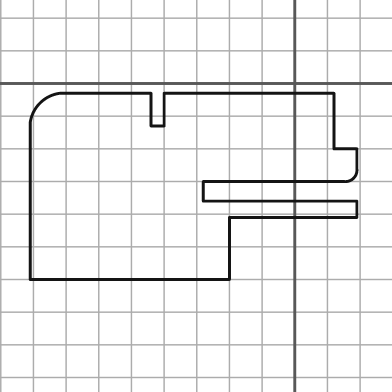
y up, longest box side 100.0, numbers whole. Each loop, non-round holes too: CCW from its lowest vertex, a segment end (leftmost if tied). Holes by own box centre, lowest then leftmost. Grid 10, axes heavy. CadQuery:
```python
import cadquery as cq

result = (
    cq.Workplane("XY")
    .moveTo(-81.0, -60.0)
    .lineTo(-20.0, -60.0)
    .lineTo(-20.0, -41.0)
    .lineTo(19.0, -41.0)
    .lineTo(19.0, -36.0)
    .lineTo(-28.0, -36.0)
    .lineTo(-28.0, -30.0)
    .lineTo(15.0, -30.0)
    .threePointArc((18.0, -29.0), (19.0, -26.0))
    .lineTo(19.0, -20.0)
    .lineTo(12.0, -20.0)
    .lineTo(12.0, -3.0)
    .lineTo(-40.0, -3.0)
    .lineTo(-40.0, -13.0)
    .lineTo(-44.0, -13.0)
    .lineTo(-44.0, -3.0)
    .lineTo(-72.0, -3.0)
    .threePointArc((-78.0, -6.0), (-81.0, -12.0))
    .close()
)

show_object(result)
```